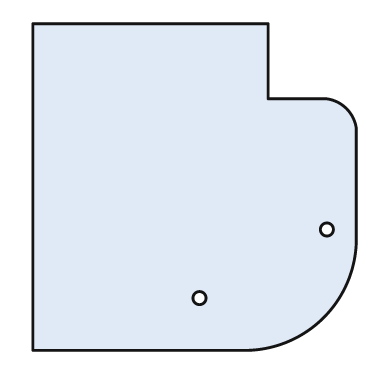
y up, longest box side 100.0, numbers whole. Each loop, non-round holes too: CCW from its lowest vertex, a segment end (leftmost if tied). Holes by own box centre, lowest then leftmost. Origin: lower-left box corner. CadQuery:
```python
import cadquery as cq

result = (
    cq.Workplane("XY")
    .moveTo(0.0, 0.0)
    .lineTo(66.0, 0.0)
    .threePointArc((89.0, 10.0), (99.0, 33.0))
    .lineTo(99.0, 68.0)
    .threePointArc((96.0, 74.0), (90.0, 77.0))
    .lineTo(72.0, 77.0)
    .lineTo(72.0, 100.0)
    .lineTo(0.0, 100.0)
    .close()
    .moveTo(51.0, 16.0)
    .circle(2.0)
    .moveTo(90.0, 37.0)
    .circle(2.0)
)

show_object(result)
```